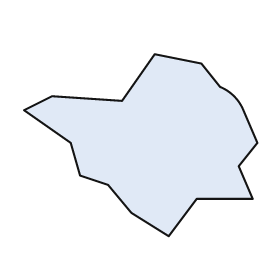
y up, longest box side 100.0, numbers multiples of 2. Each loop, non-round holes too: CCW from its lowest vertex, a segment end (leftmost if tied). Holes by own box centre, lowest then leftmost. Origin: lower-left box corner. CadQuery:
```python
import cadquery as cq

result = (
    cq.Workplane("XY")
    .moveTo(62.0, 0.0)
    .lineTo(74.0, 16.0)
    .lineTo(98.0, 16.0)
    .lineTo(92.0, 30.0)
    .lineTo(100.0, 40.0)
    .lineTo(94.0, 54.0)
    .threePointArc((90.0, 60.0), (84.0, 64.0))
    .lineTo(76.0, 74.0)
    .lineTo(56.0, 78.0)
    .lineTo(42.0, 58.0)
    .lineTo(12.0, 60.0)
    .lineTo(0.0, 54.0)
    .lineTo(20.0, 40.0)
    .lineTo(24.0, 26.0)
    .lineTo(36.0, 22.0)
    .lineTo(46.0, 10.0)
    .close()
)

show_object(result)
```